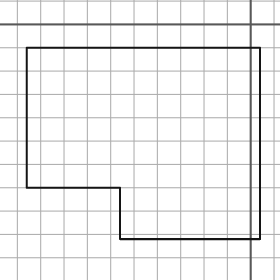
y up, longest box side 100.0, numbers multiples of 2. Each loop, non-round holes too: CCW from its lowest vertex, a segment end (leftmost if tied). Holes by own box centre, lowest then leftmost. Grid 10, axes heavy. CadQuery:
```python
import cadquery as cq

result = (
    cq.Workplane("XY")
    .moveTo(-56.0, -92.0)
    .lineTo(4.0, -92.0)
    .lineTo(4.0, -10.0)
    .lineTo(-96.0, -10.0)
    .lineTo(-96.0, -70.0)
    .lineTo(-56.0, -70.0)
    .close()
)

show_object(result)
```